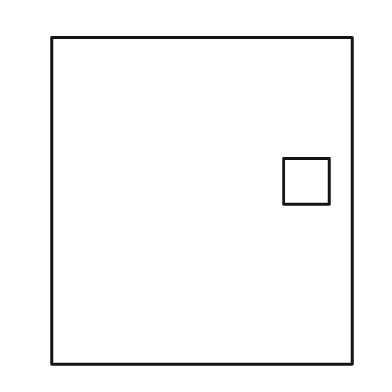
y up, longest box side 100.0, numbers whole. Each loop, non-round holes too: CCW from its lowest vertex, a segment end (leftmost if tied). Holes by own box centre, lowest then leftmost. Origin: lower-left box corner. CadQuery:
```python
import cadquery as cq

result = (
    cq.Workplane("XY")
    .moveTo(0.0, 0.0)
    .lineTo(92.0, 0.0)
    .lineTo(92.0, 100.0)
    .lineTo(0.0, 100.0)
    .close()
    .moveTo(71.0, 49.0)
    .lineTo(85.0, 49.0)
    .lineTo(85.0, 63.0)
    .lineTo(71.0, 63.0)
    .close()
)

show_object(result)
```